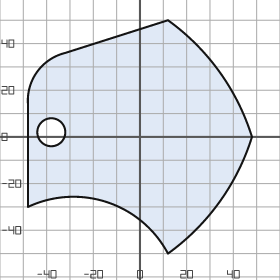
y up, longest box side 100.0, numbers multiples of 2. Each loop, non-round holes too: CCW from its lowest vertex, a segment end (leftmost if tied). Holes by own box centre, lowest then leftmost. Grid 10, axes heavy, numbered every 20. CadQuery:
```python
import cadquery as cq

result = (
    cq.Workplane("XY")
    .moveTo(12.0, -50.0)
    .threePointArc((34.0, -28.0), (48.0, 0.0))
    .threePointArc((34.0, 28.0), (12.0, 50.0))
    .lineTo(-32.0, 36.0)
    .threePointArc((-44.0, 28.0), (-48.0, 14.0))
    .lineTo(-48.0, -30.0)
    .threePointArc((-14.0, -28.0), (12.0, -50.0))
    .close()
    .moveTo(-38.0, 2.0)
    .circle(6.0)
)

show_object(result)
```